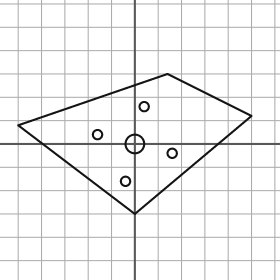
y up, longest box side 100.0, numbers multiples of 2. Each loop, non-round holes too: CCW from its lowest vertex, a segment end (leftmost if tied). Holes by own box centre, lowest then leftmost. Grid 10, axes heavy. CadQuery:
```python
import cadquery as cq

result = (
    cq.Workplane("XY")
    .moveTo(0.0, -30.0)
    .lineTo(50.0, 12.0)
    .lineTo(14.0, 30.0)
    .lineTo(-50.0, 8.0)
    .close()
    .moveTo(-4.0, -16.0)
    .circle(2.0)
    .moveTo(16.0, -4.0)
    .circle(2.0)
    .moveTo(0.0, 0.0)
    .circle(4.0)
    .moveTo(-16.0, 4.0)
    .circle(2.0)
    .moveTo(4.0, 16.0)
    .circle(2.0)
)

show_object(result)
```